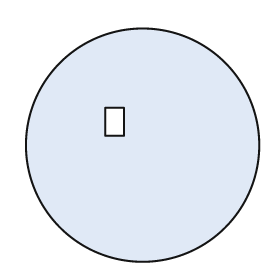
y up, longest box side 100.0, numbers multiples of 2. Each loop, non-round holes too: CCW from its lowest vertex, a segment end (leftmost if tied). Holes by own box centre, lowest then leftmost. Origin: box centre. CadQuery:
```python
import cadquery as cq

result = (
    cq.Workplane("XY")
    .moveTo(0.0, 0.0)
    .circle(50.0)
    .moveTo(-16.0, 4.0)
    .lineTo(-8.0, 4.0)
    .lineTo(-8.0, 16.0)
    .lineTo(-16.0, 16.0)
    .close()
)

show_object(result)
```